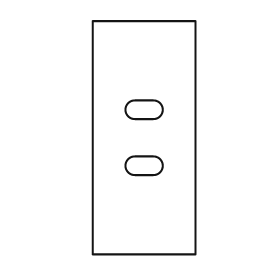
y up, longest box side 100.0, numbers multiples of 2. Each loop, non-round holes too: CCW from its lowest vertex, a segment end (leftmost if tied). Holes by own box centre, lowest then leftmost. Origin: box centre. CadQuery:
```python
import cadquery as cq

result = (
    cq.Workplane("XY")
    .moveTo(-22.0, -50.0)
    .lineTo(22.0, -50.0)
    .lineTo(22.0, 50.0)
    .lineTo(-22.0, 50.0)
    .close()
    .moveTo(-4.0, -16.0)
    .lineTo(4.0, -16.0)
    .threePointArc((8.0, -12.0), (4.0, -8.0))
    .lineTo(-4.0, -8.0)
    .threePointArc((-8.0, -12.0), (-4.0, -16.0))
    .close()
    .moveTo(-4.0, 8.0)
    .lineTo(4.0, 8.0)
    .threePointArc((8.0, 12.0), (4.0, 16.0))
    .lineTo(-4.0, 16.0)
    .threePointArc((-8.0, 12.0), (-4.0, 8.0))
    .close()
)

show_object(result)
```